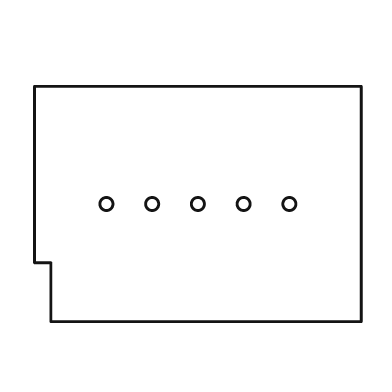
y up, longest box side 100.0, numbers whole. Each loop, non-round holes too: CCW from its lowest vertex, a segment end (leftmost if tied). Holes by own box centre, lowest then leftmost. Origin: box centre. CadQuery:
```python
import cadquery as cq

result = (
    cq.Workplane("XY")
    .moveTo(-45.0, -36.0)
    .lineTo(50.0, -36.0)
    .lineTo(50.0, 36.0)
    .lineTo(-50.0, 36.0)
    .lineTo(-50.0, -18.0)
    .lineTo(-45.0, -18.0)
    .close()
    .moveTo(-28.0, 0.0)
    .circle(2.0)
    .moveTo(-14.0, 0.0)
    .circle(2.0)
    .moveTo(0.0, 0.0)
    .circle(2.0)
    .moveTo(14.0, 0.0)
    .circle(2.0)
    .moveTo(28.0, 0.0)
    .circle(2.0)
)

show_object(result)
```